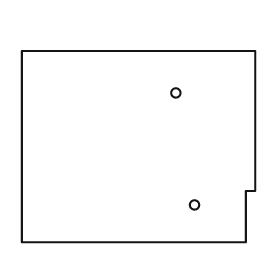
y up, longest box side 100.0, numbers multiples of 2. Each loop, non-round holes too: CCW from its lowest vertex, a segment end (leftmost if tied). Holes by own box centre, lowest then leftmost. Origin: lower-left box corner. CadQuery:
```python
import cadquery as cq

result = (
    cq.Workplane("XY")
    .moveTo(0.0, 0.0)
    .lineTo(96.0, 0.0)
    .lineTo(96.0, 22.0)
    .lineTo(100.0, 22.0)
    .lineTo(100.0, 82.0)
    .lineTo(0.0, 82.0)
    .close()
    .moveTo(74.0, 16.0)
    .circle(2.0)
    .moveTo(66.0, 64.0)
    .circle(2.0)
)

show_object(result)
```